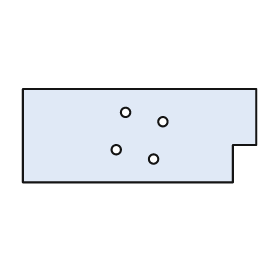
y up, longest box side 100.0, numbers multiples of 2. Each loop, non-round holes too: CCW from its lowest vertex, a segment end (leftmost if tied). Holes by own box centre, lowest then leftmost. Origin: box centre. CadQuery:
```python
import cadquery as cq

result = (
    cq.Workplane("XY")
    .moveTo(-50.0, -20.0)
    .lineTo(40.0, -20.0)
    .lineTo(40.0, -4.0)
    .lineTo(50.0, -4.0)
    .lineTo(50.0, 20.0)
    .lineTo(-50.0, 20.0)
    .close()
    .moveTo(6.0, -10.0)
    .circle(2.0)
    .moveTo(-10.0, -6.0)
    .circle(2.0)
    .moveTo(10.0, 6.0)
    .circle(2.0)
    .moveTo(-6.0, 10.0)
    .circle(2.0)
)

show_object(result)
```